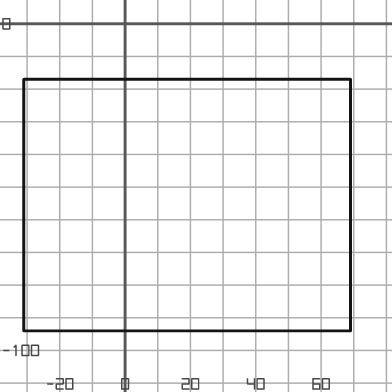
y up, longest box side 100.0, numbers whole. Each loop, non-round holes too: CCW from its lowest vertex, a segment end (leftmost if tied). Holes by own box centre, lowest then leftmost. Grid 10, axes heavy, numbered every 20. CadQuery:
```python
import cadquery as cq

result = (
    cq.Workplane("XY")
    .moveTo(-31.0, -94.0)
    .lineTo(69.0, -94.0)
    .lineTo(69.0, -17.0)
    .lineTo(-31.0, -17.0)
    .close()
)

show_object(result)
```